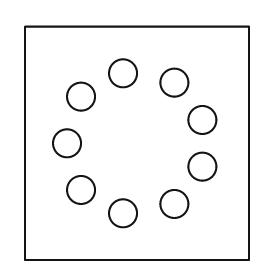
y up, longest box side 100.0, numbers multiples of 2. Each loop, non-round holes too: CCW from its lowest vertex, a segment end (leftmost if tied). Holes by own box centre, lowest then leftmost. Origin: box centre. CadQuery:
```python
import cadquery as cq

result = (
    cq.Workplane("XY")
    .moveTo(-48.0, -50.0)
    .lineTo(48.0, -50.0)
    .lineTo(48.0, 50.0)
    .lineTo(-48.0, 50.0)
    .close()
    .moveTo(-6.0, -30.0)
    .circle(6.0)
    .moveTo(16.0, -26.0)
    .circle(6.0)
    .moveTo(-24.0, -20.0)
    .circle(6.0)
    .moveTo(28.0, -10.0)
    .circle(6.0)
    .moveTo(-30.0, 0.0)
    .circle(6.0)
    .moveTo(28.0, 10.0)
    .circle(6.0)
    .moveTo(-24.0, 20.0)
    .circle(6.0)
    .moveTo(16.0, 26.0)
    .circle(6.0)
    .moveTo(-6.0, 30.0)
    .circle(6.0)
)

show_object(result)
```